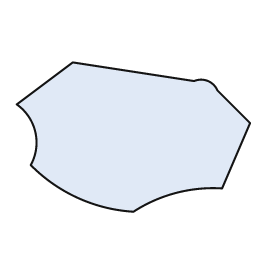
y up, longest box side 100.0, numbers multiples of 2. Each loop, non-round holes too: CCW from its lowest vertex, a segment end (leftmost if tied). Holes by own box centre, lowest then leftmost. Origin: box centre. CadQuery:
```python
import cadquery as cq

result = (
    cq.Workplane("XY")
    .moveTo(0.0, -32.0)
    .threePointArc((18.0, -24.0), (38.0, -22.0))
    .lineTo(50.0, 6.0)
    .lineTo(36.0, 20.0)
    .threePointArc((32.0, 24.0), (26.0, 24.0))
    .lineTo(-26.0, 32.0)
    .lineTo(-50.0, 14.0)
    .threePointArc((-42.0, 2.0), (-44.0, -12.0))
    .threePointArc((-24.0, -26.0), (0.0, -32.0))
    .close()
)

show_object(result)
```